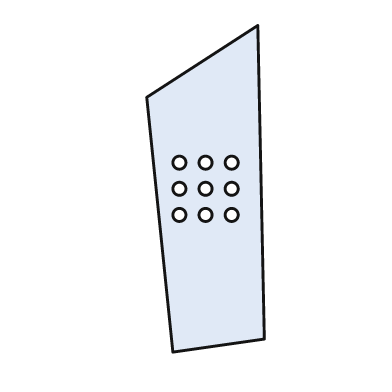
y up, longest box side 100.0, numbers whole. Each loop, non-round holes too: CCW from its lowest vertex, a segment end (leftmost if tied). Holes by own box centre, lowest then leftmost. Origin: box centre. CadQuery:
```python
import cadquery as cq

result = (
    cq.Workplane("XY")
    .moveTo(-10.0, -50.0)
    .lineTo(18.0, -46.0)
    .lineTo(16.0, 50.0)
    .lineTo(-18.0, 28.0)
    .close()
    .moveTo(-8.0, -8.0)
    .circle(2.0)
    .moveTo(0.0, -8.0)
    .circle(2.0)
    .moveTo(8.0, -8.0)
    .circle(2.0)
    .moveTo(-8.0, 0.0)
    .circle(2.0)
    .moveTo(0.0, 0.0)
    .circle(2.0)
    .moveTo(8.0, 0.0)
    .circle(2.0)
    .moveTo(-8.0, 8.0)
    .circle(2.0)
    .moveTo(0.0, 8.0)
    .circle(2.0)
    .moveTo(8.0, 8.0)
    .circle(2.0)
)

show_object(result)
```